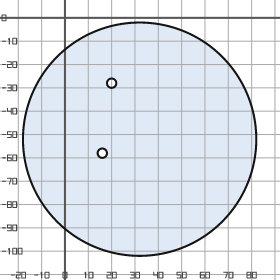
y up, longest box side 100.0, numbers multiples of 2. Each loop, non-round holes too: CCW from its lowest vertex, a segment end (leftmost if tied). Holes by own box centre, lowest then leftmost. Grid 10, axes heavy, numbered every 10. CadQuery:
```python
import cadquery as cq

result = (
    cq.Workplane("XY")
    .moveTo(32.0, -52.0)
    .circle(50.0)
    .moveTo(16.0, -58.0)
    .circle(2.0)
    .moveTo(20.0, -28.0)
    .circle(2.0)
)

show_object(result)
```